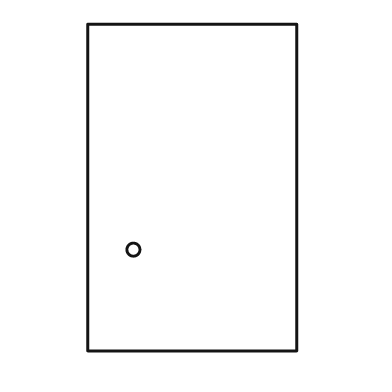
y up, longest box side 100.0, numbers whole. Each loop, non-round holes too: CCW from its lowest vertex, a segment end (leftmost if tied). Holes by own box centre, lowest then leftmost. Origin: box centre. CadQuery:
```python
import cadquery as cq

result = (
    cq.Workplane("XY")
    .moveTo(-32.0, -50.0)
    .lineTo(32.0, -50.0)
    .lineTo(32.0, 50.0)
    .lineTo(-32.0, 50.0)
    .close()
    .moveTo(-18.0, -19.0)
    .circle(2.0)
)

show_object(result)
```